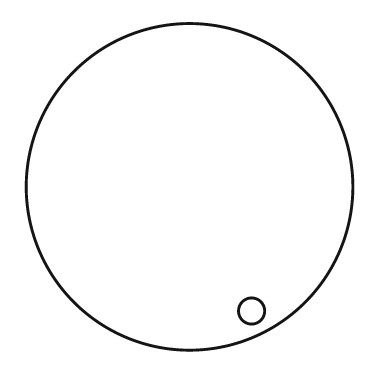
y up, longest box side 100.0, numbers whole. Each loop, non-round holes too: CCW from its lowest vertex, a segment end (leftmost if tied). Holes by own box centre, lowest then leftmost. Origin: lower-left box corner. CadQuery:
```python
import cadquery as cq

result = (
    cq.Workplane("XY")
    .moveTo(50.0, 50.0)
    .circle(50.0)
    .moveTo(69.0, 12.0)
    .circle(4.0)
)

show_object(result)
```